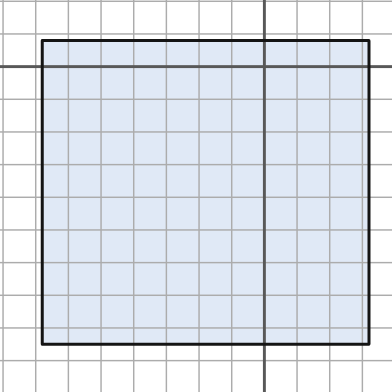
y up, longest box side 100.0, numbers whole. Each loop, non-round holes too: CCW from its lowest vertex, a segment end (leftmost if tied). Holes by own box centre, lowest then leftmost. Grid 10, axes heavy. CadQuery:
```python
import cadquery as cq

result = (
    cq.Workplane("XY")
    .moveTo(-68.0, -85.0)
    .lineTo(32.0, -85.0)
    .lineTo(32.0, 8.0)
    .lineTo(-68.0, 8.0)
    .close()
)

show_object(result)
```